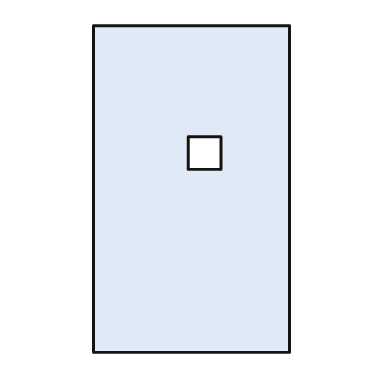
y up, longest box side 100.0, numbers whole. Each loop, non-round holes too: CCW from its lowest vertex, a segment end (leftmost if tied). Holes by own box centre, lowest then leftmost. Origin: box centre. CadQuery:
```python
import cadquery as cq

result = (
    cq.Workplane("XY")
    .moveTo(-30.0, -50.0)
    .lineTo(30.0, -50.0)
    .lineTo(30.0, 50.0)
    .lineTo(-30.0, 50.0)
    .close()
    .moveTo(-1.0, 6.0)
    .lineTo(9.0, 6.0)
    .lineTo(9.0, 16.0)
    .lineTo(-1.0, 16.0)
    .close()
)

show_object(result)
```